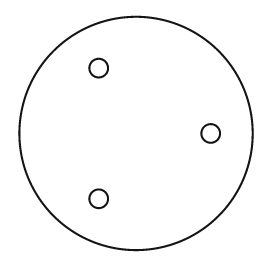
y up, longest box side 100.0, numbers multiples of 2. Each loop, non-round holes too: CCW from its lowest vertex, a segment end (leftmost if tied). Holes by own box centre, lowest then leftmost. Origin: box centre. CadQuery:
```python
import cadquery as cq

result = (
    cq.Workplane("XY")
    .moveTo(0.0, 0.0)
    .circle(50.0)
    .moveTo(-16.0, -28.0)
    .circle(4.0)
    .moveTo(32.0, 0.0)
    .circle(4.0)
    .moveTo(-16.0, 28.0)
    .circle(4.0)
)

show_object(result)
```